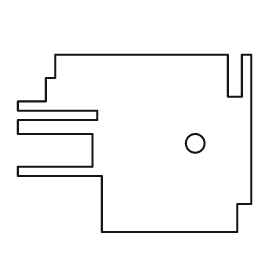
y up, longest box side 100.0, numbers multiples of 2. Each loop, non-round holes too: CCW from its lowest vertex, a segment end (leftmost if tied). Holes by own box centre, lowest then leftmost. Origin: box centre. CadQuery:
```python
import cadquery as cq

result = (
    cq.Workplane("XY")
    .moveTo(-14.0, -38.0)
    .lineTo(44.0, -38.0)
    .lineTo(44.0, -26.0)
    .lineTo(50.0, -26.0)
    .lineTo(50.0, 38.0)
    .lineTo(46.0, 38.0)
    .lineTo(46.0, 20.0)
    .lineTo(40.0, 20.0)
    .lineTo(40.0, 38.0)
    .lineTo(-34.0, 38.0)
    .lineTo(-34.0, 28.0)
    .lineTo(-38.0, 28.0)
    .lineTo(-38.0, 18.0)
    .lineTo(-50.0, 18.0)
    .lineTo(-50.0, 14.0)
    .lineTo(-16.0, 14.0)
    .lineTo(-16.0, 10.0)
    .lineTo(-50.0, 10.0)
    .lineTo(-50.0, 4.0)
    .lineTo(-18.0, 4.0)
    .lineTo(-18.0, -10.0)
    .lineTo(-50.0, -10.0)
    .lineTo(-50.0, -14.0)
    .lineTo(-14.0, -14.0)
    .close()
    .moveTo(26.0, 0.0)
    .circle(4.0)
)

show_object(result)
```